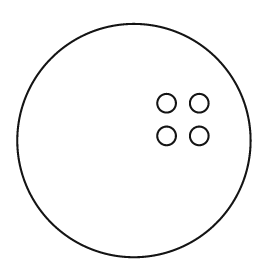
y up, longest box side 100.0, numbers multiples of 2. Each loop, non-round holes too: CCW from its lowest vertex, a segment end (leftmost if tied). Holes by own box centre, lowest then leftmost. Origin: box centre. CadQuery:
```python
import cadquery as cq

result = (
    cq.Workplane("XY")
    .moveTo(0.0, 0.0)
    .circle(50.0)
    .moveTo(14.0, 2.0)
    .circle(4.0)
    .moveTo(28.0, 2.0)
    .circle(4.0)
    .moveTo(14.0, 16.0)
    .circle(4.0)
    .moveTo(28.0, 16.0)
    .circle(4.0)
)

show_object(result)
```